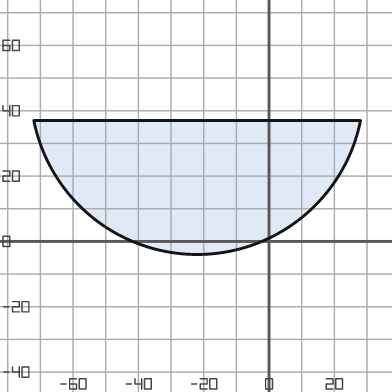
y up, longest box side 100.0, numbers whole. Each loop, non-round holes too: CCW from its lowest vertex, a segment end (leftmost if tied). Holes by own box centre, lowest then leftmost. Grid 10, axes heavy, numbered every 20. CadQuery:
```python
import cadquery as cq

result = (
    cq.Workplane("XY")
    .moveTo(-72.0, 37.0)
    .threePointArc((-22.0, -4.0), (28.0, 37.0))
    .close()
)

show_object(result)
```